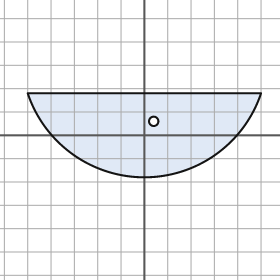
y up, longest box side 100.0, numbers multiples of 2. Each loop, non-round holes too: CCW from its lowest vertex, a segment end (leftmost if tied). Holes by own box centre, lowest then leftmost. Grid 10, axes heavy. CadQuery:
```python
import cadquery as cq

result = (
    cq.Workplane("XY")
    .moveTo(-50.0, 18.0)
    .threePointArc((0.0, -18.0), (50.0, 18.0))
    .close()
    .moveTo(4.0, 6.0)
    .circle(2.0)
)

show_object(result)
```